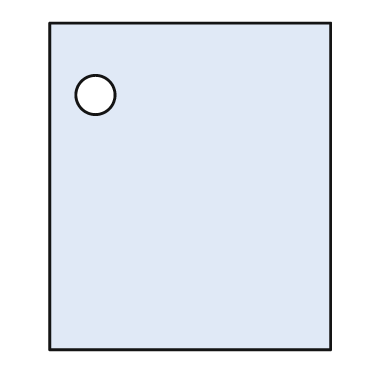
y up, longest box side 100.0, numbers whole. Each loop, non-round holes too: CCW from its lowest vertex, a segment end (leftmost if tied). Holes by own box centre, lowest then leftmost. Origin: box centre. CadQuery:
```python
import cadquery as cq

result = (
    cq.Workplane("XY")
    .moveTo(-43.0, -50.0)
    .lineTo(43.0, -50.0)
    .lineTo(43.0, 50.0)
    .lineTo(-43.0, 50.0)
    .close()
    .moveTo(-29.0, 28.0)
    .circle(6.0)
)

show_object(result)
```